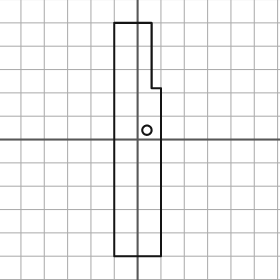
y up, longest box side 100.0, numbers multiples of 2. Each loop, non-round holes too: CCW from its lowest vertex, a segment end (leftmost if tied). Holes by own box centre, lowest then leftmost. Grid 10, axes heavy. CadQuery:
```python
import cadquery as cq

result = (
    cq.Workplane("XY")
    .moveTo(-10.0, -50.0)
    .lineTo(10.0, -50.0)
    .lineTo(10.0, 22.0)
    .lineTo(6.0, 22.0)
    .lineTo(6.0, 50.0)
    .lineTo(-10.0, 50.0)
    .close()
    .moveTo(4.0, 4.0)
    .circle(2.0)
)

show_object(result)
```